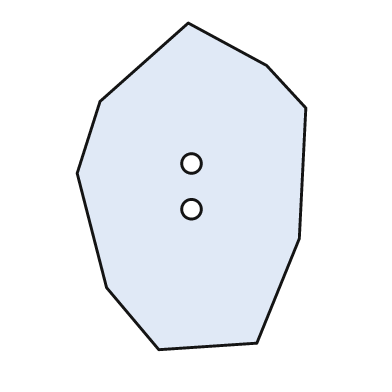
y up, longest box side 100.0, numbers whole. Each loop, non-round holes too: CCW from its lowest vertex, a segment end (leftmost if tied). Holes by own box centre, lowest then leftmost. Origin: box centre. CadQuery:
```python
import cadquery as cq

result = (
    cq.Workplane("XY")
    .moveTo(-10.0, -50.0)
    .lineTo(20.0, -48.0)
    .lineTo(33.0, -16.0)
    .lineTo(35.0, 24.0)
    .lineTo(23.0, 37.0)
    .lineTo(-1.0, 50.0)
    .lineTo(-28.0, 26.0)
    .lineTo(-35.0, 4.0)
    .lineTo(-26.0, -31.0)
    .close()
    .moveTo(0.0, -7.0)
    .circle(3.0)
    .moveTo(0.0, 7.0)
    .circle(3.0)
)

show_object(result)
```